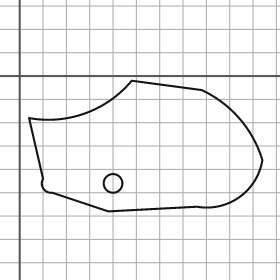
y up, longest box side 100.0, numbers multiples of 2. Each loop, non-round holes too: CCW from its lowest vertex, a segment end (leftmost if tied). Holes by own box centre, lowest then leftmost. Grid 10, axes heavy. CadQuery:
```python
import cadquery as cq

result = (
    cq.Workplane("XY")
    .moveTo(38.0, -58.0)
    .lineTo(76.0, -56.0)
    .threePointArc((94.0, -52.0), (104.0, -36.0))
    .threePointArc((94.0, -18.0), (78.0, -6.0))
    .lineTo(48.0, -2.0)
    .threePointArc((28.0, -16.0), (4.0, -18.0))
    .lineTo(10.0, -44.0)
    .threePointArc((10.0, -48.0), (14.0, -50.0))
    .close()
    .moveTo(40.0, -46.0)
    .circle(4.0)
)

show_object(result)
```